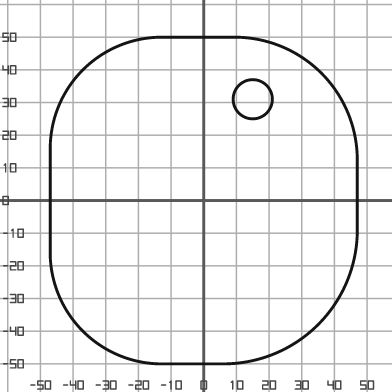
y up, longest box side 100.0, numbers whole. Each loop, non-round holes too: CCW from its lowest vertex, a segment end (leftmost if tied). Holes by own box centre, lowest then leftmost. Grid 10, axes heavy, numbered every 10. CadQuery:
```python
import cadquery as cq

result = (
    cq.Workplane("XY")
    .moveTo(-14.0, -50.0)
    .lineTo(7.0, -50.0)
    .threePointArc((35.0, -38.0), (47.0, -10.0))
    .lineTo(47.0, 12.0)
    .threePointArc((36.0, 39.0), (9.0, 50.0))
    .lineTo(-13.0, 50.0)
    .threePointArc((-37.0, 40.0), (-47.0, 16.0))
    .lineTo(-47.0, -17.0)
    .threePointArc((-37.0, -40.0), (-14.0, -50.0))
    .close()
    .moveTo(15.0, 31.0)
    .circle(6.0)
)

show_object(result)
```